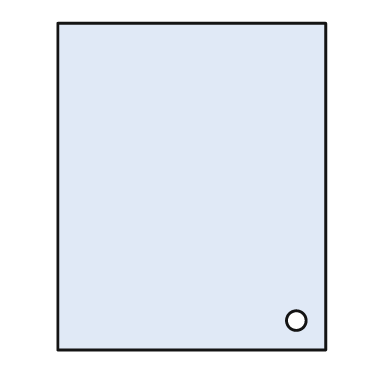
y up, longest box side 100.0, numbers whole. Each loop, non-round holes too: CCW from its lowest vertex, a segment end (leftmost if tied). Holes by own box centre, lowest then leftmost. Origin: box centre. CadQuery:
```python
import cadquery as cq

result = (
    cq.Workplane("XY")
    .moveTo(-41.0, -50.0)
    .lineTo(41.0, -50.0)
    .lineTo(41.0, 50.0)
    .lineTo(-41.0, 50.0)
    .close()
    .moveTo(32.0, -41.0)
    .circle(3.0)
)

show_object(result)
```